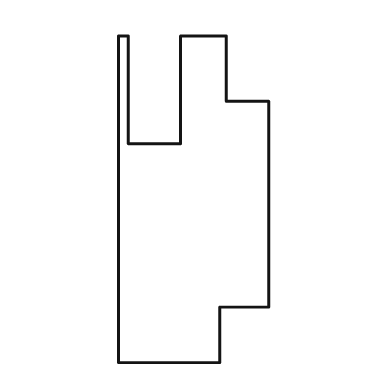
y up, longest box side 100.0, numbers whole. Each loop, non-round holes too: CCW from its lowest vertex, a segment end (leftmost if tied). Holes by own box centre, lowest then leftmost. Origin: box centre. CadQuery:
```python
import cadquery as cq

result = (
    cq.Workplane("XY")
    .moveTo(-23.0, -50.0)
    .lineTo(8.0, -50.0)
    .lineTo(8.0, -33.0)
    .lineTo(23.0, -33.0)
    .lineTo(23.0, 30.0)
    .lineTo(10.0, 30.0)
    .lineTo(10.0, 50.0)
    .lineTo(-4.0, 50.0)
    .lineTo(-4.0, 17.0)
    .lineTo(-20.0, 17.0)
    .lineTo(-20.0, 50.0)
    .lineTo(-23.0, 50.0)
    .close()
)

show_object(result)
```